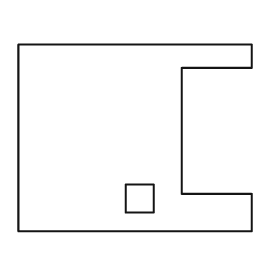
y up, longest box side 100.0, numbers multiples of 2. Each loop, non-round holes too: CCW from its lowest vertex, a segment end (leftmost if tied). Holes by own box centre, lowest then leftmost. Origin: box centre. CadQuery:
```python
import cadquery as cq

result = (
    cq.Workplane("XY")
    .moveTo(-50.0, -40.0)
    .lineTo(50.0, -40.0)
    .lineTo(50.0, -24.0)
    .lineTo(20.0, -24.0)
    .lineTo(20.0, 30.0)
    .lineTo(50.0, 30.0)
    .lineTo(50.0, 40.0)
    .lineTo(-50.0, 40.0)
    .close()
    .moveTo(-4.0, -32.0)
    .lineTo(8.0, -32.0)
    .lineTo(8.0, -20.0)
    .lineTo(-4.0, -20.0)
    .close()
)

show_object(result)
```